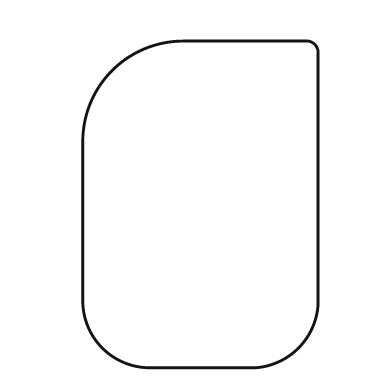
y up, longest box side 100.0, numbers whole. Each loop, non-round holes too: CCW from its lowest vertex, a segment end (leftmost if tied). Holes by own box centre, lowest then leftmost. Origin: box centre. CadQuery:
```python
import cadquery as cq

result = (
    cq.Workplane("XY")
    .moveTo(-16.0, -50.0)
    .lineTo(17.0, -50.0)
    .threePointArc((30.0, -44.0), (36.0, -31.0))
    .lineTo(36.0, 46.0)
    .threePointArc((35.0, 49.0), (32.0, 50.0))
    .lineTo(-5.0, 50.0)
    .threePointArc((-27.0, 41.0), (-36.0, 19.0))
    .lineTo(-36.0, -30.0)
    .threePointArc((-30.0, -44.0), (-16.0, -50.0))
    .close()
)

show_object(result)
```